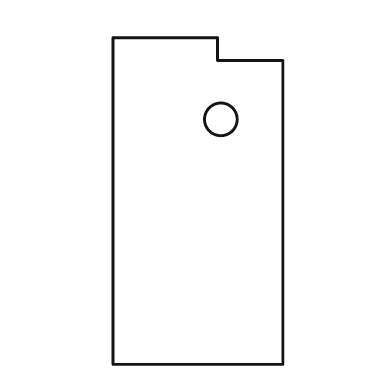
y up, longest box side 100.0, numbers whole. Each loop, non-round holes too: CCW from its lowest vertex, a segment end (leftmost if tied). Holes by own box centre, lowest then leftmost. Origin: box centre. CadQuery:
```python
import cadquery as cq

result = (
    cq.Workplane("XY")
    .moveTo(-26.0, -50.0)
    .lineTo(26.0, -50.0)
    .lineTo(26.0, 43.0)
    .lineTo(6.0, 43.0)
    .lineTo(6.0, 50.0)
    .lineTo(-26.0, 50.0)
    .close()
    .moveTo(7.0, 25.0)
    .circle(5.0)
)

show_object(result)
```